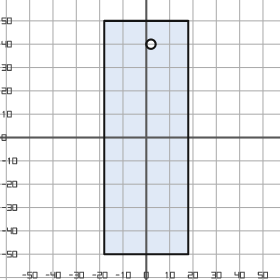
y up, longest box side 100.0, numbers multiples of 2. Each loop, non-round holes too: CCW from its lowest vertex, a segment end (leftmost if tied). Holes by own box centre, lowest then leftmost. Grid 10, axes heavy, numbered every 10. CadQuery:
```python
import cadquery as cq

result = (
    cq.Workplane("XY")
    .moveTo(-18.0, -50.0)
    .lineTo(18.0, -50.0)
    .lineTo(18.0, 50.0)
    .lineTo(-18.0, 50.0)
    .close()
    .moveTo(2.0, 40.0)
    .circle(2.0)
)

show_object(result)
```